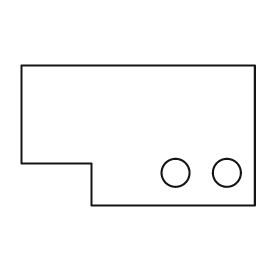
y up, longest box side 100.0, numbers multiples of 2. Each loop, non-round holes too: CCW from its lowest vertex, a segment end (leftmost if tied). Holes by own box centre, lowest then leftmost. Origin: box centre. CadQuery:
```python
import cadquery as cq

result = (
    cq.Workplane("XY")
    .moveTo(-20.0, -30.0)
    .lineTo(50.0, -30.0)
    .lineTo(50.0, 30.0)
    .lineTo(-50.0, 30.0)
    .lineTo(-50.0, -12.0)
    .lineTo(-20.0, -12.0)
    .close()
    .moveTo(16.0, -16.0)
    .circle(6.0)
    .moveTo(38.0, -16.0)
    .circle(6.0)
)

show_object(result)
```